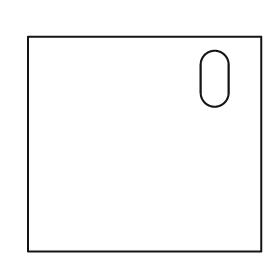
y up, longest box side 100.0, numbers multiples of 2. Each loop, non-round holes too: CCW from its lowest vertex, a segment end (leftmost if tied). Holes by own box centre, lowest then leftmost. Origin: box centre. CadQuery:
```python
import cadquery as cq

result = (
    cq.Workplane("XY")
    .moveTo(-50.0, -46.0)
    .lineTo(50.0, -46.0)
    .lineTo(50.0, 46.0)
    .lineTo(-50.0, 46.0)
    .close()
    .moveTo(24.0, 22.0)
    .threePointArc((30.0, 16.0), (36.0, 22.0))
    .lineTo(36.0, 34.0)
    .threePointArc((30.0, 40.0), (24.0, 34.0))
    .close()
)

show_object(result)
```